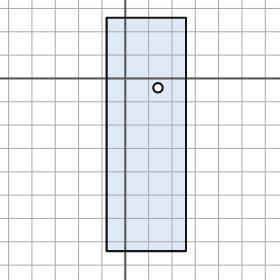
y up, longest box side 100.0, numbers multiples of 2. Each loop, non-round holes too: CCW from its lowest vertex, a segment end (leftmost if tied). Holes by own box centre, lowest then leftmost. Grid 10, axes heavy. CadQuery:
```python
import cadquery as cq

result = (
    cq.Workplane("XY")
    .moveTo(-8.0, -74.0)
    .lineTo(26.0, -74.0)
    .lineTo(26.0, 26.0)
    .lineTo(-8.0, 26.0)
    .close()
    .moveTo(14.0, -4.0)
    .circle(2.0)
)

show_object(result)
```